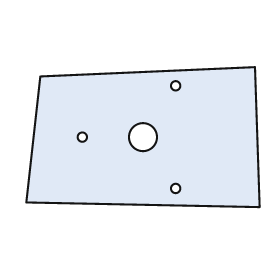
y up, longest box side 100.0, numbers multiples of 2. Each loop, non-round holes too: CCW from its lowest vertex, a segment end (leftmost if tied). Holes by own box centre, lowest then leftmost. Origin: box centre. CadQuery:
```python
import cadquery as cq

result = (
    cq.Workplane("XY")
    .moveTo(50.0, -30.0)
    .lineTo(48.0, 30.0)
    .lineTo(-44.0, 26.0)
    .lineTo(-50.0, -28.0)
    .close()
    .moveTo(14.0, -22.0)
    .circle(2.0)
    .moveTo(-26.0, 0.0)
    .circle(2.0)
    .moveTo(0.0, 0.0)
    .circle(6.0)
    .moveTo(14.0, 22.0)
    .circle(2.0)
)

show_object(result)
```